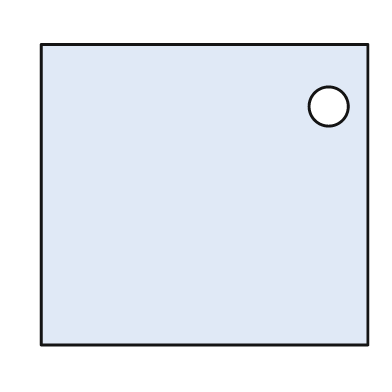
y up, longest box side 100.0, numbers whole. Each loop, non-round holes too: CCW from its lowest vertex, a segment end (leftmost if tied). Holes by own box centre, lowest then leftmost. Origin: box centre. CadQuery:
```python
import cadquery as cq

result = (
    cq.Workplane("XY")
    .moveTo(-50.0, -46.0)
    .lineTo(50.0, -46.0)
    .lineTo(50.0, 46.0)
    .lineTo(-50.0, 46.0)
    .close()
    .moveTo(38.0, 27.0)
    .circle(6.0)
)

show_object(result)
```